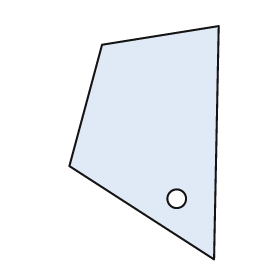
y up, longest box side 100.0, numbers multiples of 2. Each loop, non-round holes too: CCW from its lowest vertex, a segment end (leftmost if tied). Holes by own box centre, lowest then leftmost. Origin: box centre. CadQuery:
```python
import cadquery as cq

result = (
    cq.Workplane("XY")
    .moveTo(30.0, -50.0)
    .lineTo(32.0, 50.0)
    .lineTo(-18.0, 42.0)
    .lineTo(-32.0, -10.0)
    .close()
    .moveTo(14.0, -24.0)
    .circle(4.0)
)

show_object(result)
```